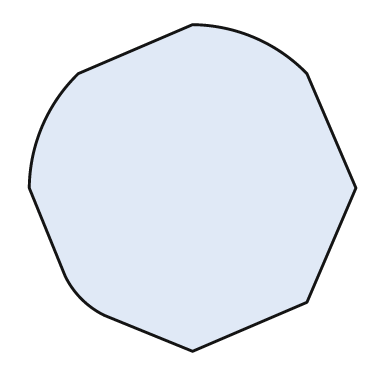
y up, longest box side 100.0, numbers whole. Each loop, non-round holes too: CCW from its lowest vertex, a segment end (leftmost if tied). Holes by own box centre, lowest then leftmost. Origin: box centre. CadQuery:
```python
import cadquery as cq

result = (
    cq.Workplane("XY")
    .moveTo(0.0, -50.0)
    .lineTo(35.0, -35.0)
    .lineTo(50.0, 0.0)
    .lineTo(35.0, 35.0)
    .threePointArc((19.0, 46.0), (0.0, 50.0))
    .lineTo(-35.0, 35.0)
    .threePointArc((-46.0, 19.0), (-50.0, 0.0))
    .lineTo(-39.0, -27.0)
    .threePointArc((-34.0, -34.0), (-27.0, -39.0))
    .close()
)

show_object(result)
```